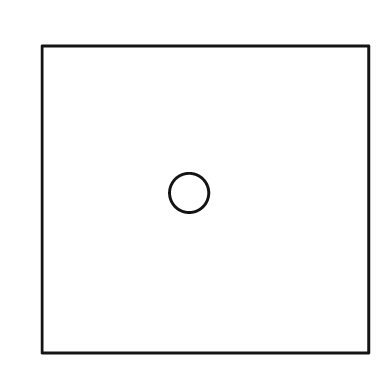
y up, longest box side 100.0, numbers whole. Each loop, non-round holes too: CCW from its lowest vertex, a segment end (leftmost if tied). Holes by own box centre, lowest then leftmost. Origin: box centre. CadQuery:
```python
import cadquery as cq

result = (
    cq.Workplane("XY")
    .moveTo(-50.0, -47.0)
    .lineTo(50.0, -47.0)
    .lineTo(50.0, 47.0)
    .lineTo(-50.0, 47.0)
    .close()
    .moveTo(-5.0, 2.0)
    .circle(6.0)
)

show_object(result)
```